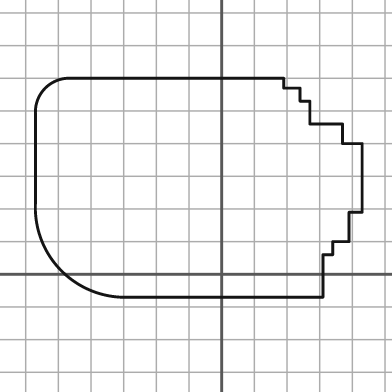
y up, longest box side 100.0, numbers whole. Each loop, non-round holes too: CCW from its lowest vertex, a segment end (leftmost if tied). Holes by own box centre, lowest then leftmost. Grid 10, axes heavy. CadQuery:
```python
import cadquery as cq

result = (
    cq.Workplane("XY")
    .moveTo(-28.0, -7.0)
    .lineTo(31.0, -7.0)
    .lineTo(31.0, 6.0)
    .lineTo(34.0, 6.0)
    .lineTo(34.0, 10.0)
    .lineTo(39.0, 10.0)
    .lineTo(39.0, 19.0)
    .lineTo(43.0, 19.0)
    .lineTo(43.0, 40.0)
    .lineTo(37.0, 40.0)
    .lineTo(37.0, 46.0)
    .lineTo(27.0, 46.0)
    .lineTo(27.0, 53.0)
    .lineTo(24.0, 53.0)
    .lineTo(24.0, 57.0)
    .lineTo(19.0, 57.0)
    .lineTo(19.0, 60.0)
    .lineTo(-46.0, 60.0)
    .threePointArc((-54.0, 57.0), (-57.0, 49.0))
    .lineTo(-57.0, 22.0)
    .threePointArc((-49.0, 1.0), (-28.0, -7.0))
    .close()
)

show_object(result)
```